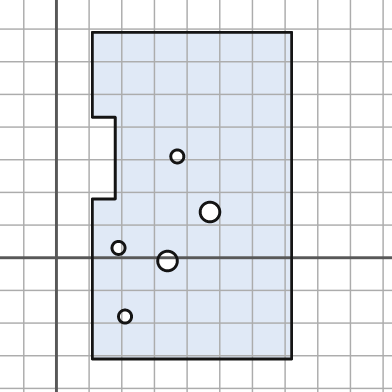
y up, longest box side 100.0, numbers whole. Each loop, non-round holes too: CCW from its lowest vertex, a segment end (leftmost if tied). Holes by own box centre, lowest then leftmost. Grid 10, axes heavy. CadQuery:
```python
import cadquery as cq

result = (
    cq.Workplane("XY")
    .moveTo(11.0, -31.0)
    .lineTo(72.0, -31.0)
    .lineTo(72.0, 69.0)
    .lineTo(11.0, 69.0)
    .lineTo(11.0, 43.0)
    .lineTo(18.0, 43.0)
    .lineTo(18.0, 18.0)
    .lineTo(11.0, 18.0)
    .close()
    .moveTo(21.0, -18.0)
    .circle(2.0)
    .moveTo(34.0, -1.0)
    .circle(3.0)
    .moveTo(19.0, 3.0)
    .circle(2.0)
    .moveTo(47.0, 14.0)
    .circle(3.0)
    .moveTo(37.0, 31.0)
    .circle(2.0)
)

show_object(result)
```